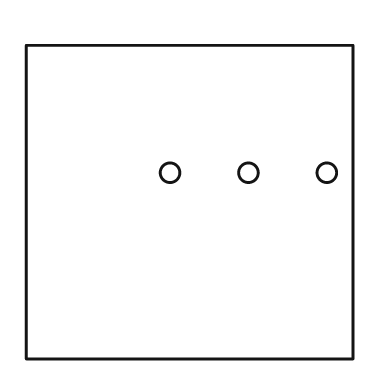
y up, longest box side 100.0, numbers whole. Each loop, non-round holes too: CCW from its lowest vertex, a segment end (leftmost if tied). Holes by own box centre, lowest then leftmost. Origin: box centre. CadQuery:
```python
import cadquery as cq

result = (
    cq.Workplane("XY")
    .moveTo(-50.0, -48.0)
    .lineTo(50.0, -48.0)
    .lineTo(50.0, 48.0)
    .lineTo(-50.0, 48.0)
    .close()
    .moveTo(-6.0, 9.0)
    .circle(3.0)
    .moveTo(18.0, 9.0)
    .circle(3.0)
    .moveTo(42.0, 9.0)
    .circle(3.0)
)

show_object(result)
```